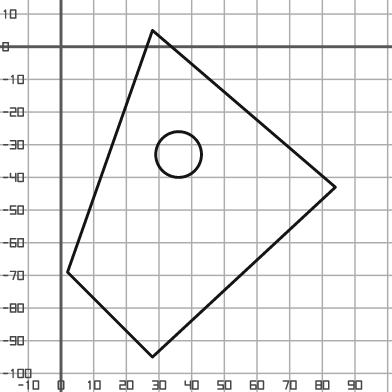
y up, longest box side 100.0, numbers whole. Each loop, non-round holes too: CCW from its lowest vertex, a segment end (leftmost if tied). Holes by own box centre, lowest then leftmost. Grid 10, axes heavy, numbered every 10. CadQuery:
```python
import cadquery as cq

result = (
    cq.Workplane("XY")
    .moveTo(28.0, -95.0)
    .lineTo(84.0, -43.0)
    .lineTo(28.0, 5.0)
    .lineTo(2.0, -69.0)
    .close()
    .moveTo(36.0, -33.0)
    .circle(7.0)
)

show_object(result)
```